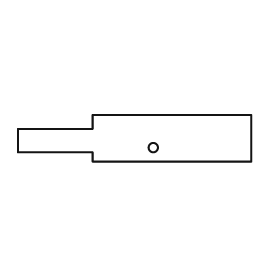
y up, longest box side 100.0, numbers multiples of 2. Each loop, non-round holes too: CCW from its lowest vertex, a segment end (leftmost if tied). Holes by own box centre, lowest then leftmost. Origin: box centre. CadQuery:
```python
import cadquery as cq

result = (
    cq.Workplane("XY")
    .moveTo(-18.0, -10.0)
    .lineTo(50.0, -10.0)
    .lineTo(50.0, 10.0)
    .lineTo(-18.0, 10.0)
    .lineTo(-18.0, 4.0)
    .lineTo(-50.0, 4.0)
    .lineTo(-50.0, -6.0)
    .lineTo(-18.0, -6.0)
    .close()
    .moveTo(8.0, -4.0)
    .circle(2.0)
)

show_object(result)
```